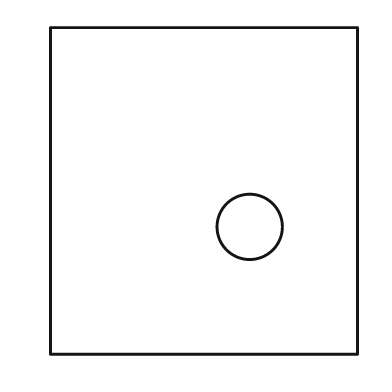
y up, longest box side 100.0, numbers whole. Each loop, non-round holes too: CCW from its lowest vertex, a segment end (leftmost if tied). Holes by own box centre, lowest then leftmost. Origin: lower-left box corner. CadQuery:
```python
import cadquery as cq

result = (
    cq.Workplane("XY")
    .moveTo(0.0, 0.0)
    .lineTo(94.0, 0.0)
    .lineTo(94.0, 100.0)
    .lineTo(0.0, 100.0)
    .close()
    .moveTo(61.0, 39.0)
    .circle(10.0)
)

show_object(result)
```